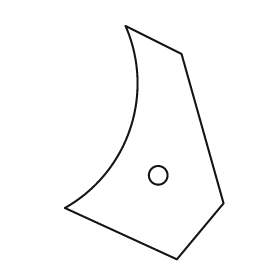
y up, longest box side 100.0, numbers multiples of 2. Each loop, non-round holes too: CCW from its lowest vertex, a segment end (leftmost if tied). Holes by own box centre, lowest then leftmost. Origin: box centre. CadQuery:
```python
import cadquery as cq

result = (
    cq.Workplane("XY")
    .moveTo(14.0, -50.0)
    .lineTo(34.0, -26.0)
    .lineTo(16.0, 38.0)
    .lineTo(-8.0, 50.0)
    .threePointArc((-6.0, 6.0), (-34.0, -28.0))
    .close()
    .moveTo(6.0, -14.0)
    .circle(4.0)
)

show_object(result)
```